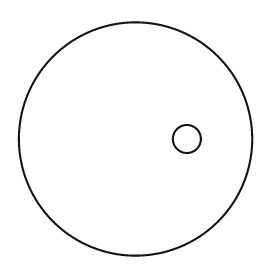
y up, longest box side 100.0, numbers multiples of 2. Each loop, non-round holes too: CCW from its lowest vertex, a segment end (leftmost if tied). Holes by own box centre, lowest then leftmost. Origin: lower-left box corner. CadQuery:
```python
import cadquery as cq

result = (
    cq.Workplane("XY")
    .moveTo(50.0, 50.0)
    .circle(50.0)
    .moveTo(72.0, 50.0)
    .circle(6.0)
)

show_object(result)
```